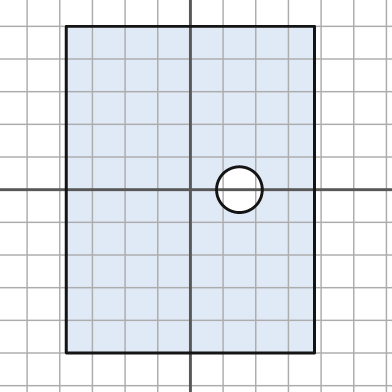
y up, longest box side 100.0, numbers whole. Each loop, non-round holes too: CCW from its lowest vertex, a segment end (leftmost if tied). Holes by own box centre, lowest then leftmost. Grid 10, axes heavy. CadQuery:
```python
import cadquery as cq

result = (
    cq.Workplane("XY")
    .moveTo(-38.0, -50.0)
    .lineTo(38.0, -50.0)
    .lineTo(38.0, 50.0)
    .lineTo(-38.0, 50.0)
    .close()
    .moveTo(15.0, 0.0)
    .circle(7.0)
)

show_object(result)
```